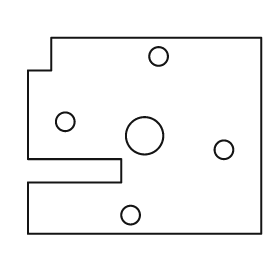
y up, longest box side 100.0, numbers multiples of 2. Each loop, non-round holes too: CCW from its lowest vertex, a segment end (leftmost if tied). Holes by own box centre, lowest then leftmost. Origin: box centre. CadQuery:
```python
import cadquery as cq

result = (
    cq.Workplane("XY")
    .moveTo(-50.0, -42.0)
    .lineTo(50.0, -42.0)
    .lineTo(50.0, 42.0)
    .lineTo(-40.0, 42.0)
    .lineTo(-40.0, 28.0)
    .lineTo(-50.0, 28.0)
    .lineTo(-50.0, -10.0)
    .lineTo(-10.0, -10.0)
    .lineTo(-10.0, -20.0)
    .lineTo(-50.0, -20.0)
    .close()
    .moveTo(-6.0, -34.0)
    .circle(4.0)
    .moveTo(34.0, -6.0)
    .circle(4.0)
    .moveTo(0.0, 0.0)
    .circle(8.0)
    .moveTo(-34.0, 6.0)
    .circle(4.0)
    .moveTo(6.0, 34.0)
    .circle(4.0)
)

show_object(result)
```